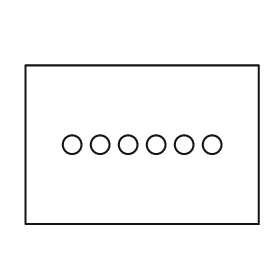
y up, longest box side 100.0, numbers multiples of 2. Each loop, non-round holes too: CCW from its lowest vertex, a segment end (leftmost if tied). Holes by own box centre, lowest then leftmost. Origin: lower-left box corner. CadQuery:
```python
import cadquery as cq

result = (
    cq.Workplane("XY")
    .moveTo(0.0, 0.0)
    .lineTo(100.0, 0.0)
    .lineTo(100.0, 68.0)
    .lineTo(0.0, 68.0)
    .close()
    .moveTo(20.0, 34.0)
    .circle(4.0)
    .moveTo(32.0, 34.0)
    .circle(4.0)
    .moveTo(44.0, 34.0)
    .circle(4.0)
    .moveTo(56.0, 34.0)
    .circle(4.0)
    .moveTo(68.0, 34.0)
    .circle(4.0)
    .moveTo(80.0, 34.0)
    .circle(4.0)
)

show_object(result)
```